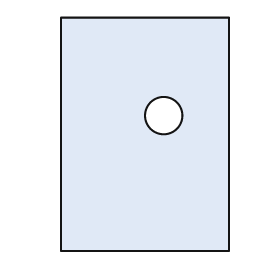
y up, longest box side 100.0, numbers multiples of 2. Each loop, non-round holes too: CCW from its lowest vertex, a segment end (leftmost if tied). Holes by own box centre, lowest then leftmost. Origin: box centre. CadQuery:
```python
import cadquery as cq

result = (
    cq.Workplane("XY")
    .moveTo(-36.0, -50.0)
    .lineTo(36.0, -50.0)
    .lineTo(36.0, 50.0)
    .lineTo(-36.0, 50.0)
    .close()
    .moveTo(8.0, 8.0)
    .circle(8.0)
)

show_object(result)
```